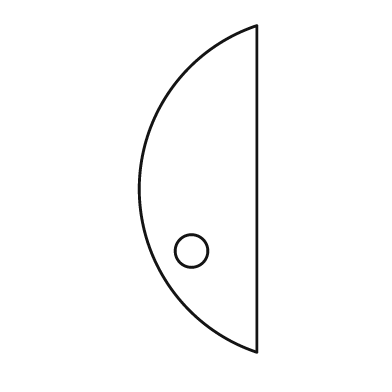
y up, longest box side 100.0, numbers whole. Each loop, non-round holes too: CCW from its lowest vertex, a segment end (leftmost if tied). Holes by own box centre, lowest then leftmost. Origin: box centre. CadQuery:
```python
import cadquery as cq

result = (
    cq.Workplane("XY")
    .moveTo(18.0, -50.0)
    .lineTo(18.0, 50.0)
    .threePointArc((-18.0, 0.0), (18.0, -50.0))
    .close()
    .moveTo(-2.0, -19.0)
    .circle(5.0)
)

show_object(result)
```